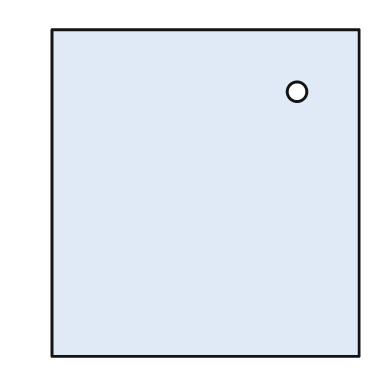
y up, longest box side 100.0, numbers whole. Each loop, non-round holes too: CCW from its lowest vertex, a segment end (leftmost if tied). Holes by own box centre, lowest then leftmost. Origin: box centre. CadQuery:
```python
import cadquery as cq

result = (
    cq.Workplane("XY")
    .moveTo(-47.0, -50.0)
    .lineTo(47.0, -50.0)
    .lineTo(47.0, 50.0)
    .lineTo(-47.0, 50.0)
    .close()
    .moveTo(28.0, 31.0)
    .circle(3.0)
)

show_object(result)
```